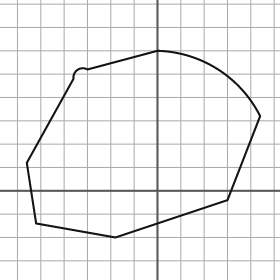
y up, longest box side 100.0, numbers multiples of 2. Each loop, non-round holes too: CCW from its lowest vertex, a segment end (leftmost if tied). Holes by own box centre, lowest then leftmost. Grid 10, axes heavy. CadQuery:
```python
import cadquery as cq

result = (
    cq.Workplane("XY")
    .moveTo(-18.0, -20.0)
    .lineTo(30.0, -4.0)
    .lineTo(44.0, 32.0)
    .threePointArc((26.0, 52.0), (0.0, 60.0))
    .lineTo(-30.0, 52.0)
    .threePointArc((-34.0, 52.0), (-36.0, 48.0))
    .lineTo(-56.0, 12.0)
    .lineTo(-52.0, -14.0)
    .close()
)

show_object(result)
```